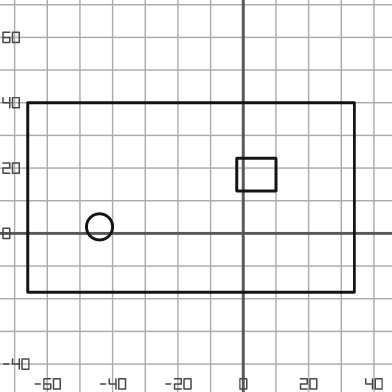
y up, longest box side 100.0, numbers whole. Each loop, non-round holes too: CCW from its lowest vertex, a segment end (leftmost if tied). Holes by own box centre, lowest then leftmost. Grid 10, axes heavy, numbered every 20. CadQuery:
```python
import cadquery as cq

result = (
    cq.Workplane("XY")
    .moveTo(-66.0, -18.0)
    .lineTo(34.0, -18.0)
    .lineTo(34.0, 40.0)
    .lineTo(-66.0, 40.0)
    .close()
    .moveTo(-44.0, 2.0)
    .circle(4.0)
    .moveTo(-2.0, 13.0)
    .lineTo(10.0, 13.0)
    .lineTo(10.0, 23.0)
    .lineTo(-2.0, 23.0)
    .close()
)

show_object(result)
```